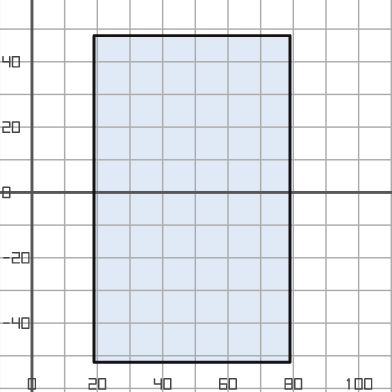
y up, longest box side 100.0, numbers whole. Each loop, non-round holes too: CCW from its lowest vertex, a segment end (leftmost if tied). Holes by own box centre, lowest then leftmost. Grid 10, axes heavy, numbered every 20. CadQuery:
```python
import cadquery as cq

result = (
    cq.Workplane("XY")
    .moveTo(19.0, -52.0)
    .lineTo(79.0, -52.0)
    .lineTo(79.0, 48.0)
    .lineTo(19.0, 48.0)
    .close()
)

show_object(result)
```